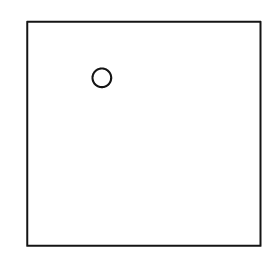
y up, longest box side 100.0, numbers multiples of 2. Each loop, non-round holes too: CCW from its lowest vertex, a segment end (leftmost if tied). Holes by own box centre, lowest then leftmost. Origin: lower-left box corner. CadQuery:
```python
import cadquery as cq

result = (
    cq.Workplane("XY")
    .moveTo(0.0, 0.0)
    .lineTo(100.0, 0.0)
    .lineTo(100.0, 96.0)
    .lineTo(0.0, 96.0)
    .close()
    .moveTo(32.0, 72.0)
    .circle(4.0)
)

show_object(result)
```